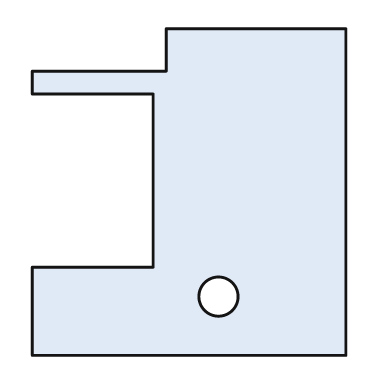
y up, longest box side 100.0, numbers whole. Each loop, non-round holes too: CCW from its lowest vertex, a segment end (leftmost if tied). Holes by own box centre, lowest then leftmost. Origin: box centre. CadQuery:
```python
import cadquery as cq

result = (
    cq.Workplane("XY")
    .moveTo(-48.0, -50.0)
    .lineTo(48.0, -50.0)
    .lineTo(48.0, 50.0)
    .lineTo(-7.0, 50.0)
    .lineTo(-7.0, 37.0)
    .lineTo(-48.0, 37.0)
    .lineTo(-48.0, 30.0)
    .lineTo(-11.0, 30.0)
    .lineTo(-11.0, -23.0)
    .lineTo(-48.0, -23.0)
    .close()
    .moveTo(9.0, -32.0)
    .circle(6.0)
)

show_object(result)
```